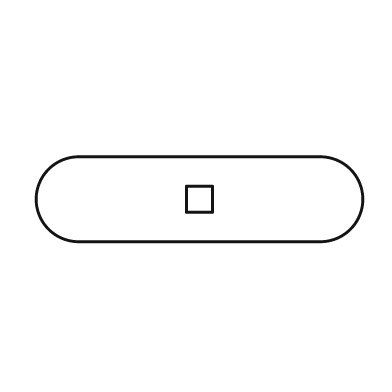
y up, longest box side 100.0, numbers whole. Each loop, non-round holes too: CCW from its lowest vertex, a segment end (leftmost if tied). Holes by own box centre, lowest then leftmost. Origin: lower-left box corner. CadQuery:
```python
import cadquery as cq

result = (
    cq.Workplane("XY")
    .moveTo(13.0, 0.0)
    .lineTo(87.0, 0.0)
    .threePointArc((100.0, 13.0), (87.0, 26.0))
    .lineTo(13.0, 26.0)
    .threePointArc((0.0, 13.0), (13.0, 0.0))
    .close()
    .moveTo(46.0, 9.0)
    .lineTo(54.0, 9.0)
    .lineTo(54.0, 17.0)
    .lineTo(46.0, 17.0)
    .close()
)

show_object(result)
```